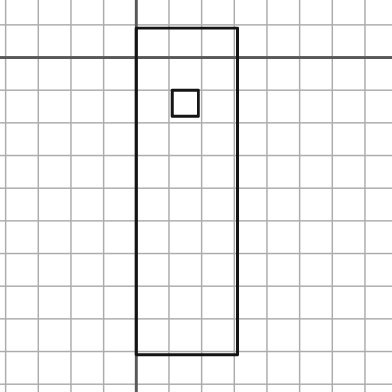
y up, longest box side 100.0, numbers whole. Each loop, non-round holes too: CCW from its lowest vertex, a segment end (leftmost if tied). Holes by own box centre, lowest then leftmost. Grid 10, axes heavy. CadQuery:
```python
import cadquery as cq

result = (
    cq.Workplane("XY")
    .moveTo(0.0, -91.0)
    .lineTo(31.0, -91.0)
    .lineTo(31.0, 9.0)
    .lineTo(0.0, 9.0)
    .close()
    .moveTo(11.0, -18.0)
    .lineTo(19.0, -18.0)
    .lineTo(19.0, -10.0)
    .lineTo(11.0, -10.0)
    .close()
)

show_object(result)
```